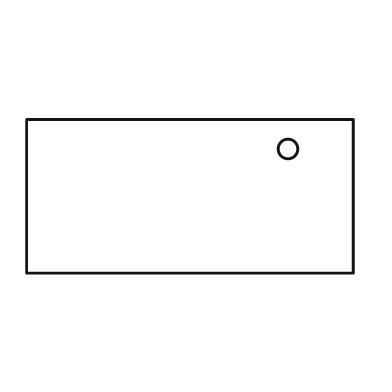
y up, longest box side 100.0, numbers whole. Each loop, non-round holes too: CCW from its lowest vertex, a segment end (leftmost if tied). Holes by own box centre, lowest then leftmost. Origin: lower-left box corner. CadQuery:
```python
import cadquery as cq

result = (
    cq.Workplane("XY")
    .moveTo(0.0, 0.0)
    .lineTo(100.0, 0.0)
    .lineTo(100.0, 47.0)
    .lineTo(0.0, 47.0)
    .close()
    .moveTo(80.0, 38.0)
    .circle(3.0)
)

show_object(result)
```